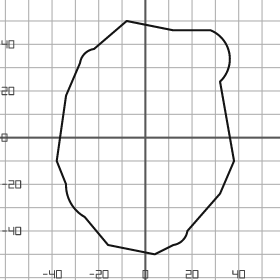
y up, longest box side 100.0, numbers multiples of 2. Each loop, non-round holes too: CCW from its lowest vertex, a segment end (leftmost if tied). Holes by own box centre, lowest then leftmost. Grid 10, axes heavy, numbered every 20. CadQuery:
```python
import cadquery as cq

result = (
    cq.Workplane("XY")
    .moveTo(4.0, -50.0)
    .lineTo(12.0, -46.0)
    .threePointArc((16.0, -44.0), (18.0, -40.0))
    .lineTo(32.0, -24.0)
    .lineTo(38.0, -10.0)
    .lineTo(32.0, 24.0)
    .threePointArc((36.0, 36.0), (28.0, 46.0))
    .lineTo(12.0, 46.0)
    .lineTo(-8.0, 50.0)
    .lineTo(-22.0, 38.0)
    .threePointArc((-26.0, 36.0), (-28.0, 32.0))
    .lineTo(-34.0, 18.0)
    .lineTo(-38.0, -10.0)
    .lineTo(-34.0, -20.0)
    .threePointArc((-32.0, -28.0), (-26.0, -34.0))
    .lineTo(-16.0, -46.0)
    .close()
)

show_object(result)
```